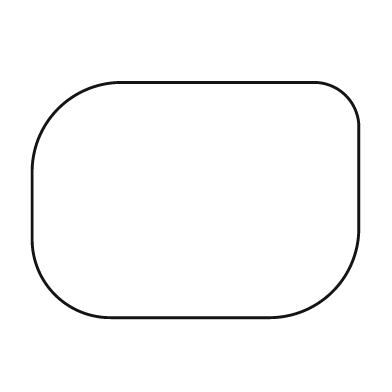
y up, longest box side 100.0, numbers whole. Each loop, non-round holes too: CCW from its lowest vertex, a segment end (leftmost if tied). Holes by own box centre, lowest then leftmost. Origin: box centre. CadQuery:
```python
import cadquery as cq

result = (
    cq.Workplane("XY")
    .moveTo(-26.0, -36.0)
    .lineTo(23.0, -36.0)
    .threePointArc((42.0, -28.0), (50.0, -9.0))
    .lineTo(50.0, 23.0)
    .threePointArc((46.0, 32.0), (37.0, 36.0))
    .lineTo(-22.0, 36.0)
    .threePointArc((-42.0, 28.0), (-50.0, 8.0))
    .lineTo(-50.0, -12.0)
    .threePointArc((-43.0, -29.0), (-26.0, -36.0))
    .close()
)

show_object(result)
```